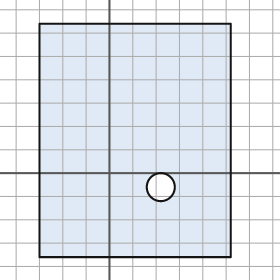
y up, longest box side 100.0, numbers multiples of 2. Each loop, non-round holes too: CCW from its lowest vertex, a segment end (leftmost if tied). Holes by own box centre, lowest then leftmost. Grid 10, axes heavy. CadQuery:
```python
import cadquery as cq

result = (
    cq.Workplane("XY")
    .moveTo(-30.0, -36.0)
    .lineTo(52.0, -36.0)
    .lineTo(52.0, 64.0)
    .lineTo(-30.0, 64.0)
    .close()
    .moveTo(22.0, -6.0)
    .circle(6.0)
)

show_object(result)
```